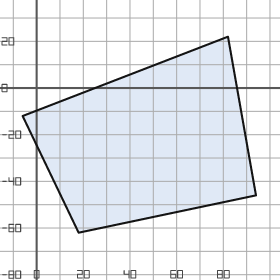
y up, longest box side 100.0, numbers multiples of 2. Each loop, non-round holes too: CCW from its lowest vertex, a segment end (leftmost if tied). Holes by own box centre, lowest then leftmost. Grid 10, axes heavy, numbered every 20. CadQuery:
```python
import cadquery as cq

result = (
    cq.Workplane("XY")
    .moveTo(18.0, -62.0)
    .lineTo(94.0, -46.0)
    .lineTo(82.0, 22.0)
    .lineTo(-6.0, -12.0)
    .close()
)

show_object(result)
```